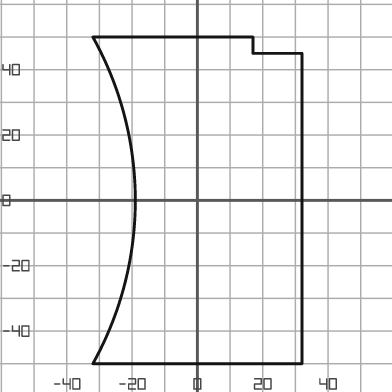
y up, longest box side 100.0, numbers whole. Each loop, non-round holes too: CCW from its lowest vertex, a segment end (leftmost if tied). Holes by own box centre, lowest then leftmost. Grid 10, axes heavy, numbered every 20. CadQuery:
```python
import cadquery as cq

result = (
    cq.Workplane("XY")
    .moveTo(-32.0, -50.0)
    .lineTo(32.0, -50.0)
    .lineTo(32.0, 45.0)
    .lineTo(17.0, 45.0)
    .lineTo(17.0, 50.0)
    .lineTo(-32.0, 50.0)
    .threePointArc((-19.0, 0.0), (-32.0, -50.0))
    .close()
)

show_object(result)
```